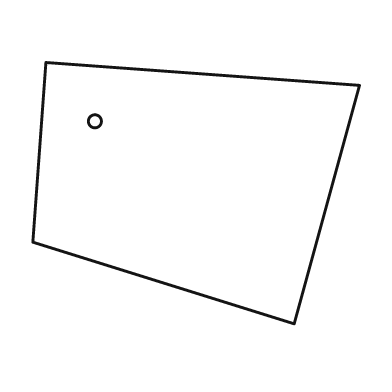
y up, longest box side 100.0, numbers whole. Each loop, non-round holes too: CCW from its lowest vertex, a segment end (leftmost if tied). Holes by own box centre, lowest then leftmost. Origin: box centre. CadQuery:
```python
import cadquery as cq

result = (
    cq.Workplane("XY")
    .moveTo(30.0, -40.0)
    .lineTo(50.0, 33.0)
    .lineTo(-46.0, 40.0)
    .lineTo(-50.0, -15.0)
    .close()
    .moveTo(-31.0, 22.0)
    .circle(2.0)
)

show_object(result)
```